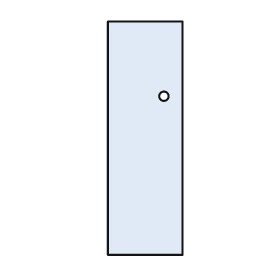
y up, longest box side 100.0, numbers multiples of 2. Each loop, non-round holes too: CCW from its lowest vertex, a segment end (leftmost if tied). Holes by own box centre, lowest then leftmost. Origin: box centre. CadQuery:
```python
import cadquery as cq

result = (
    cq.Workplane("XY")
    .moveTo(-16.0, -50.0)
    .lineTo(16.0, -50.0)
    .lineTo(16.0, 50.0)
    .lineTo(-16.0, 50.0)
    .close()
    .moveTo(8.0, 18.0)
    .circle(2.0)
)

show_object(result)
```